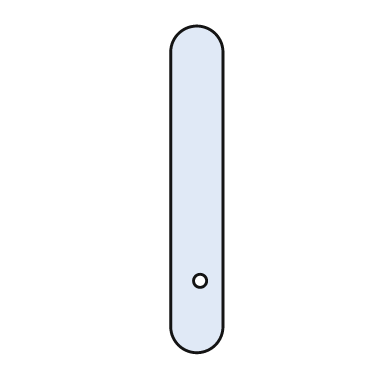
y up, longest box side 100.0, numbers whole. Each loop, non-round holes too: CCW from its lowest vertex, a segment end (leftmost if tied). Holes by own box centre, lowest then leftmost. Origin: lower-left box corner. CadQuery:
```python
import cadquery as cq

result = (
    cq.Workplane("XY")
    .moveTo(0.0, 8.0)
    .threePointArc((8.0, 0.0), (16.0, 8.0))
    .lineTo(16.0, 92.0)
    .threePointArc((8.0, 100.0), (0.0, 92.0))
    .close()
    .moveTo(9.0, 22.0)
    .circle(2.0)
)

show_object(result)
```